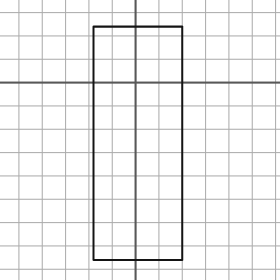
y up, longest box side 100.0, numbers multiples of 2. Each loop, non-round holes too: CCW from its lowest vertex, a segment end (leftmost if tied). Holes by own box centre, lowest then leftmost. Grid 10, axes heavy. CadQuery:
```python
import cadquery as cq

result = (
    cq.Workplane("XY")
    .moveTo(-18.0, -76.0)
    .lineTo(20.0, -76.0)
    .lineTo(20.0, 24.0)
    .lineTo(-18.0, 24.0)
    .close()
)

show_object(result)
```